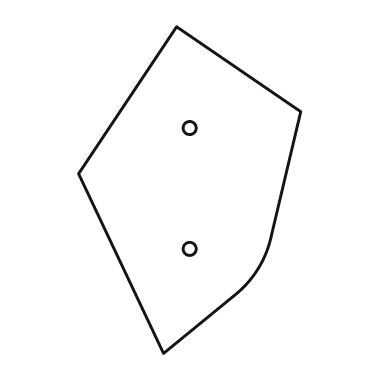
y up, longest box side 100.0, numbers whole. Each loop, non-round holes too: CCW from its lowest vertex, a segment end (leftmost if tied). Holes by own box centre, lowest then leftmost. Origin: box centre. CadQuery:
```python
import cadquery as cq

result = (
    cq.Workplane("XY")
    .moveTo(-8.0, -50.0)
    .lineTo(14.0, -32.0)
    .threePointArc((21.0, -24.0), (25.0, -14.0))
    .lineTo(34.0, 24.0)
    .lineTo(-4.0, 50.0)
    .lineTo(-34.0, 5.0)
    .close()
    .moveTo(0.0, -18.0)
    .circle(2.0)
    .moveTo(0.0, 19.0)
    .circle(2.0)
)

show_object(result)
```